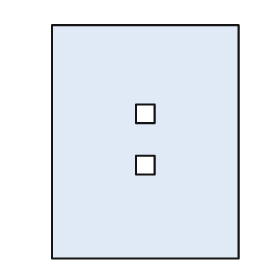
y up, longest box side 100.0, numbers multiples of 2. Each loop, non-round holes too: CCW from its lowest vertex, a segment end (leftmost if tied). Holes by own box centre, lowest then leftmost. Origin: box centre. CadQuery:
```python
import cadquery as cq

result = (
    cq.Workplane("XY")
    .moveTo(-40.0, -50.0)
    .lineTo(40.0, -50.0)
    .lineTo(40.0, 50.0)
    .lineTo(-40.0, 50.0)
    .close()
    .moveTo(-4.0, -14.0)
    .lineTo(4.0, -14.0)
    .lineTo(4.0, -6.0)
    .lineTo(-4.0, -6.0)
    .close()
    .moveTo(-4.0, 8.0)
    .lineTo(4.0, 8.0)
    .lineTo(4.0, 16.0)
    .lineTo(-4.0, 16.0)
    .close()
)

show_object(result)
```